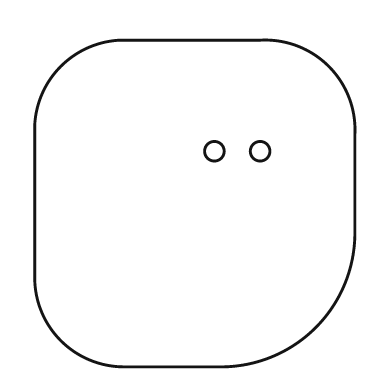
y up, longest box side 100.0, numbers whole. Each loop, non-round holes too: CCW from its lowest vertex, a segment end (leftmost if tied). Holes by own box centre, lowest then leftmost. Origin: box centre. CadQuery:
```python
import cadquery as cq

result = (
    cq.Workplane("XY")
    .moveTo(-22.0, -50.0)
    .lineTo(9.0, -50.0)
    .threePointArc((37.0, -38.0), (49.0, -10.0))
    .lineTo(49.0, 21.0)
    .threePointArc((41.0, 42.0), (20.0, 50.0))
    .lineTo(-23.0, 50.0)
    .threePointArc((-41.0, 42.0), (-49.0, 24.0))
    .lineTo(-49.0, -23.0)
    .threePointArc((-41.0, -42.0), (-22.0, -50.0))
    .close()
    .moveTo(6.0, 16.0)
    .circle(3.0)
    .moveTo(20.0, 16.0)
    .circle(3.0)
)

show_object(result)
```